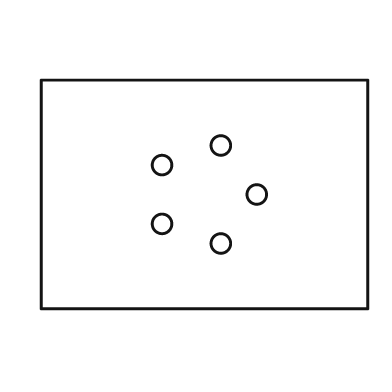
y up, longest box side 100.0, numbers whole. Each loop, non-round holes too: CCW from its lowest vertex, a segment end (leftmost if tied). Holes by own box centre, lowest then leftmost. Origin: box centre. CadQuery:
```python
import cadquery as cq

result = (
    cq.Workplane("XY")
    .moveTo(-50.0, -35.0)
    .lineTo(50.0, -35.0)
    .lineTo(50.0, 35.0)
    .lineTo(-50.0, 35.0)
    .close()
    .moveTo(5.0, -15.0)
    .circle(3.0)
    .moveTo(-13.0, -9.0)
    .circle(3.0)
    .moveTo(16.0, 0.0)
    .circle(3.0)
    .moveTo(-13.0, 9.0)
    .circle(3.0)
    .moveTo(5.0, 15.0)
    .circle(3.0)
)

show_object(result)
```